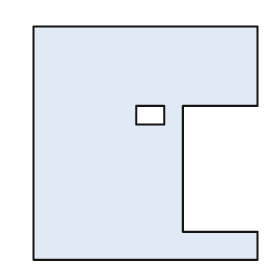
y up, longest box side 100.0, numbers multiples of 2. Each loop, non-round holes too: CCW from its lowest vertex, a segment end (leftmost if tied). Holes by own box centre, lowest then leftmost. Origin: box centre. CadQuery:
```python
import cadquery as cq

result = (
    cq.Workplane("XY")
    .moveTo(-48.0, -50.0)
    .lineTo(48.0, -50.0)
    .lineTo(48.0, -38.0)
    .lineTo(16.0, -38.0)
    .lineTo(16.0, 16.0)
    .lineTo(48.0, 16.0)
    .lineTo(48.0, 50.0)
    .lineTo(-48.0, 50.0)
    .close()
    .moveTo(-4.0, 8.0)
    .lineTo(8.0, 8.0)
    .lineTo(8.0, 16.0)
    .lineTo(-4.0, 16.0)
    .close()
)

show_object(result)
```